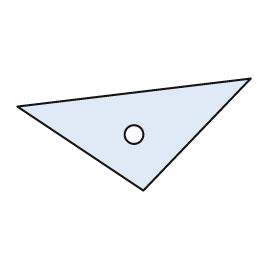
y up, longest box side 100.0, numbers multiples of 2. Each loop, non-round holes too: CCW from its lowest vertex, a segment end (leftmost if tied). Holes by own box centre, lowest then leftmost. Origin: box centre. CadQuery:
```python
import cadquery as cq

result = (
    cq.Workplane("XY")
    .moveTo(4.0, -24.0)
    .lineTo(50.0, 24.0)
    .lineTo(-50.0, 12.0)
    .close()
    .moveTo(0.0, 0.0)
    .circle(4.0)
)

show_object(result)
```